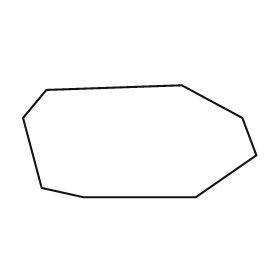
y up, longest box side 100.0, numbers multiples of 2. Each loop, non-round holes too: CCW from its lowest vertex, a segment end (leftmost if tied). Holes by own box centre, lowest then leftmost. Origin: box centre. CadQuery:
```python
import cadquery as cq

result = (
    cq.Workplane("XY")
    .moveTo(-24.0, -24.0)
    .lineTo(24.0, -24.0)
    .lineTo(50.0, -6.0)
    .lineTo(44.0, 10.0)
    .lineTo(18.0, 24.0)
    .lineTo(-40.0, 22.0)
    .lineTo(-50.0, 10.0)
    .lineTo(-42.0, -20.0)
    .close()
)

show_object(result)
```